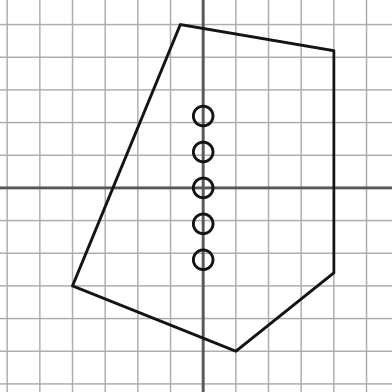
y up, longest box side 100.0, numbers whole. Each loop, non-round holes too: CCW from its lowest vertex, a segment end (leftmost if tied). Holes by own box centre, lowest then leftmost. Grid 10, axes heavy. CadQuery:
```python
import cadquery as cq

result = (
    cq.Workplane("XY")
    .moveTo(10.0, -50.0)
    .lineTo(40.0, -26.0)
    .lineTo(40.0, 42.0)
    .lineTo(-7.0, 50.0)
    .lineTo(-40.0, -30.0)
    .close()
    .moveTo(0.0, -22.0)
    .circle(3.0)
    .moveTo(0.0, -11.0)
    .circle(3.0)
    .moveTo(0.0, 0.0)
    .circle(3.0)
    .moveTo(0.0, 11.0)
    .circle(3.0)
    .moveTo(0.0, 22.0)
    .circle(3.0)
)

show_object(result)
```